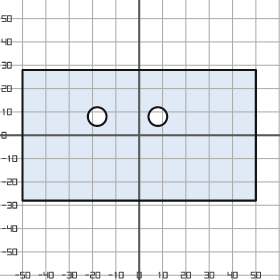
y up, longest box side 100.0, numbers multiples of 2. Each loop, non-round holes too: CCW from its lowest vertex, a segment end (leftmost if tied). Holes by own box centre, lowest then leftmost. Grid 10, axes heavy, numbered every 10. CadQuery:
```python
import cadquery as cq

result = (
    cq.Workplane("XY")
    .moveTo(-50.0, -28.0)
    .lineTo(50.0, -28.0)
    .lineTo(50.0, 28.0)
    .lineTo(-50.0, 28.0)
    .close()
    .moveTo(-18.0, 8.0)
    .circle(4.0)
    .moveTo(8.0, 8.0)
    .circle(4.0)
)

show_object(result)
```